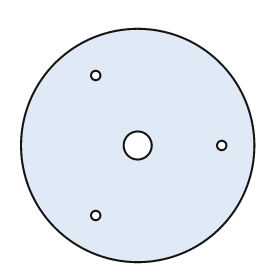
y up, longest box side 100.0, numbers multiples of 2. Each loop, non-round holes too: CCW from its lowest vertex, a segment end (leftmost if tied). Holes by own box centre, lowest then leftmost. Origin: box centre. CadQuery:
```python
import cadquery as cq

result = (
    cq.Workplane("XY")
    .moveTo(0.0, 0.0)
    .circle(50.0)
    .moveTo(-18.0, -30.0)
    .circle(2.0)
    .moveTo(0.0, 0.0)
    .circle(6.0)
    .moveTo(36.0, 0.0)
    .circle(2.0)
    .moveTo(-18.0, 30.0)
    .circle(2.0)
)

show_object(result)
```